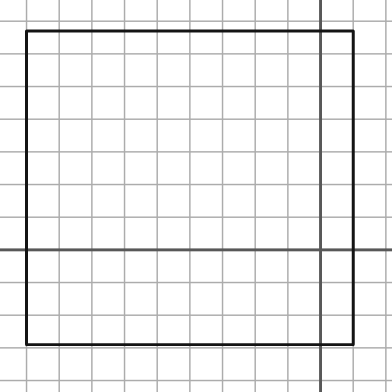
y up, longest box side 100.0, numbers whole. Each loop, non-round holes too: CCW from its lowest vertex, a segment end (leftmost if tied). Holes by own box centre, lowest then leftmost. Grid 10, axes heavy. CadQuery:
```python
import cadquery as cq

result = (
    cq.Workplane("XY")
    .moveTo(-90.0, -29.0)
    .lineTo(10.0, -29.0)
    .lineTo(10.0, 67.0)
    .lineTo(-90.0, 67.0)
    .close()
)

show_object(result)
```